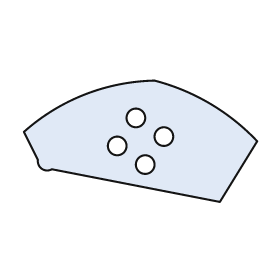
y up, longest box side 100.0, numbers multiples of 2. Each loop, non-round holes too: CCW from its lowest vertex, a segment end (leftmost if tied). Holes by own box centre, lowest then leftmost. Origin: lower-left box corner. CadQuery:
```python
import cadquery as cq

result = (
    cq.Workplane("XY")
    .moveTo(84.0, 0.0)
    .lineTo(100.0, 26.0)
    .threePointArc((80.0, 42.0), (56.0, 52.0))
    .threePointArc((26.0, 46.0), (0.0, 30.0))
    .lineTo(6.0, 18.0)
    .threePointArc((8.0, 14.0), (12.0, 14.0))
    .close()
    .moveTo(52.0, 16.0)
    .circle(4.0)
    .moveTo(40.0, 24.0)
    .circle(4.0)
    .moveTo(60.0, 28.0)
    .circle(4.0)
    .moveTo(48.0, 36.0)
    .circle(4.0)
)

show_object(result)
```